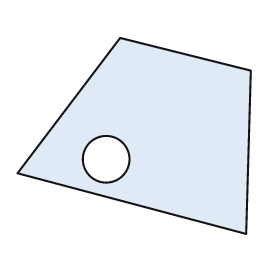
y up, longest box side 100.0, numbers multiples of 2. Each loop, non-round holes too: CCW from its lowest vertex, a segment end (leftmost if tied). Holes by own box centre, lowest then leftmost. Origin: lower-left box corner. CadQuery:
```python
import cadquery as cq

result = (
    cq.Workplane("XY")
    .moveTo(98.0, 0.0)
    .lineTo(100.0, 70.0)
    .lineTo(44.0, 84.0)
    .lineTo(0.0, 26.0)
    .close()
    .moveTo(38.0, 32.0)
    .circle(10.0)
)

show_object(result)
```